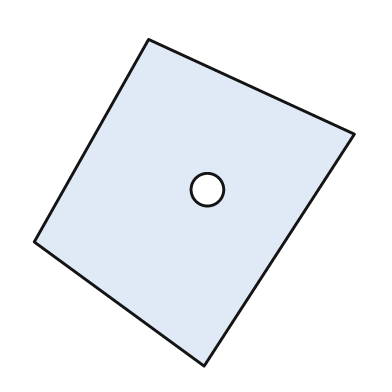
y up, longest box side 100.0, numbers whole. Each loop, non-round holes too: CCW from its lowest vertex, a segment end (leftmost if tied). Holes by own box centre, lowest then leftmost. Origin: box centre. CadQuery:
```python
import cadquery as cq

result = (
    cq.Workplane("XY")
    .moveTo(3.0, -50.0)
    .lineTo(49.0, 21.0)
    .lineTo(-14.0, 50.0)
    .lineTo(-49.0, -12.0)
    .close()
    .moveTo(4.0, 4.0)
    .circle(5.0)
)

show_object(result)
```